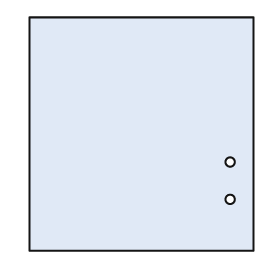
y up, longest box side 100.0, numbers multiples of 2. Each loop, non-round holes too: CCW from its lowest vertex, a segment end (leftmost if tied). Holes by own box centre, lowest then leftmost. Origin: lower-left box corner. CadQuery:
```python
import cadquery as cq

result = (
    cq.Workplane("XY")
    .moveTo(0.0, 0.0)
    .lineTo(96.0, 0.0)
    .lineTo(96.0, 100.0)
    .lineTo(0.0, 100.0)
    .close()
    .moveTo(86.0, 22.0)
    .circle(2.0)
    .moveTo(86.0, 38.0)
    .circle(2.0)
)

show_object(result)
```